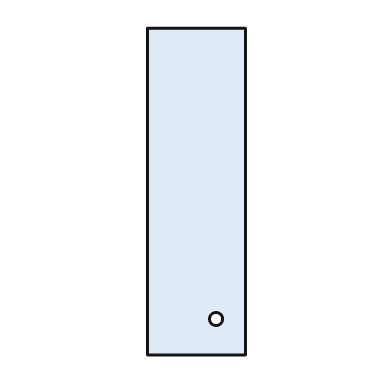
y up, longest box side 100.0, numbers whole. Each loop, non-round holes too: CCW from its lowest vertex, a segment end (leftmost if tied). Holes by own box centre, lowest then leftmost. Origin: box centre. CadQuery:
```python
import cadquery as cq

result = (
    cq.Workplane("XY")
    .moveTo(-15.0, -50.0)
    .lineTo(15.0, -50.0)
    .lineTo(15.0, 50.0)
    .lineTo(-15.0, 50.0)
    .close()
    .moveTo(6.0, -39.0)
    .circle(2.0)
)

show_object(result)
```